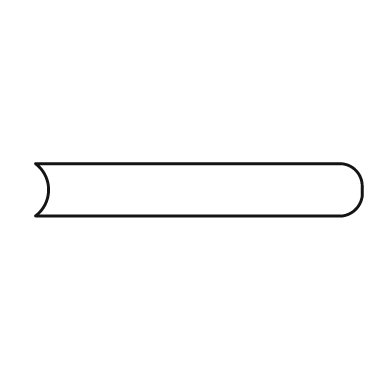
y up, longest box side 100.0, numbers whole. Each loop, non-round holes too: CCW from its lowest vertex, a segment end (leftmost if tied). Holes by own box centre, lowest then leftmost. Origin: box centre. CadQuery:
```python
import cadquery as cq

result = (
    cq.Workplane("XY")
    .moveTo(-50.0, -8.0)
    .lineTo(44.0, -8.0)
    .threePointArc((48.0, -6.0), (50.0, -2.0))
    .lineTo(50.0, 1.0)
    .threePointArc((48.0, 6.0), (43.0, 8.0))
    .lineTo(-50.0, 8.0)
    .threePointArc((-46.0, 0.0), (-50.0, -8.0))
    .close()
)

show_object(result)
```